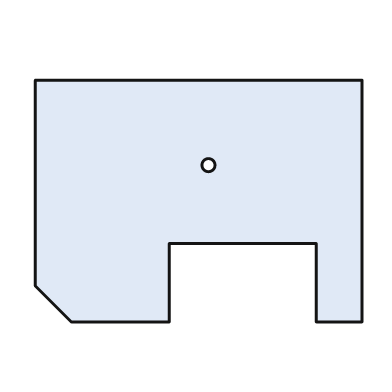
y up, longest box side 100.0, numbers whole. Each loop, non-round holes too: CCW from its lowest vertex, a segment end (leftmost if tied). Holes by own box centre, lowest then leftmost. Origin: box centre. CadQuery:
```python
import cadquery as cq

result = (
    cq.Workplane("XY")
    .moveTo(-39.0, -37.0)
    .lineTo(-9.0, -37.0)
    .lineTo(-9.0, -13.0)
    .lineTo(36.0, -13.0)
    .lineTo(36.0, -37.0)
    .lineTo(50.0, -37.0)
    .lineTo(50.0, 37.0)
    .lineTo(-50.0, 37.0)
    .lineTo(-50.0, -26.0)
    .close()
    .moveTo(3.0, 11.0)
    .circle(2.0)
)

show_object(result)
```